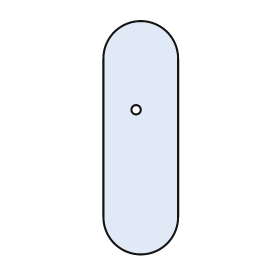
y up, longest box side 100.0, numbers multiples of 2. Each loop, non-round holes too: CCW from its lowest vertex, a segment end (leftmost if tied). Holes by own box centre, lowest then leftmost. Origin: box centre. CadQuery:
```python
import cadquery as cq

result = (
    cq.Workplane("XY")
    .moveTo(-16.0, -34.0)
    .threePointArc((0.0, -50.0), (16.0, -34.0))
    .lineTo(16.0, 34.0)
    .threePointArc((0.0, 50.0), (-16.0, 34.0))
    .close()
    .moveTo(-2.0, 12.0)
    .circle(2.0)
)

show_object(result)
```